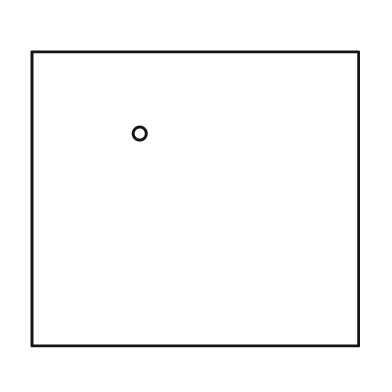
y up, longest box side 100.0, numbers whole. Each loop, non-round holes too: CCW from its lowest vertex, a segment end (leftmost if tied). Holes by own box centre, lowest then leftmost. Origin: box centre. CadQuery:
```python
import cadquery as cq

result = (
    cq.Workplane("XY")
    .moveTo(-50.0, -45.0)
    .lineTo(50.0, -45.0)
    .lineTo(50.0, 45.0)
    .lineTo(-50.0, 45.0)
    .close()
    .moveTo(-17.0, 20.0)
    .circle(2.0)
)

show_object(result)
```